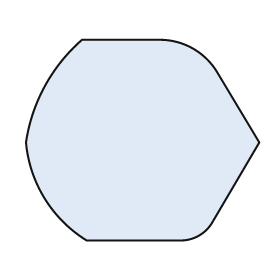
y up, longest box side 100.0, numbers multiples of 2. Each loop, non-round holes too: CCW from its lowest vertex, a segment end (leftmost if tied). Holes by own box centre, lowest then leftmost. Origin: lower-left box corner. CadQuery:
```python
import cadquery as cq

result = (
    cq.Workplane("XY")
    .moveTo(26.0, 0.0)
    .lineTo(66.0, 0.0)
    .threePointArc((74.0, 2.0), (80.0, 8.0))
    .lineTo(100.0, 42.0)
    .lineTo(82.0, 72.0)
    .threePointArc((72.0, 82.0), (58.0, 86.0))
    .lineTo(24.0, 86.0)
    .threePointArc((8.0, 66.0), (0.0, 42.0))
    .threePointArc((8.0, 18.0), (26.0, 0.0))
    .close()
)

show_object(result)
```